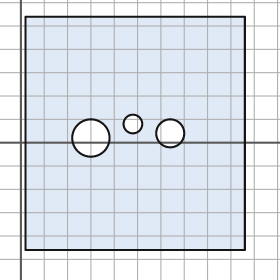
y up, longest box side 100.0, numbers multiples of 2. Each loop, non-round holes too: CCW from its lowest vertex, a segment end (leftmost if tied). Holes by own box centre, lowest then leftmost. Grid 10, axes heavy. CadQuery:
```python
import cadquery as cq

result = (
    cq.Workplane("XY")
    .moveTo(2.0, -46.0)
    .lineTo(96.0, -46.0)
    .lineTo(96.0, 54.0)
    .lineTo(2.0, 54.0)
    .close()
    .moveTo(30.0, 2.0)
    .circle(8.0)
    .moveTo(64.0, 4.0)
    .circle(6.0)
    .moveTo(48.0, 8.0)
    .circle(4.0)
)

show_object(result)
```